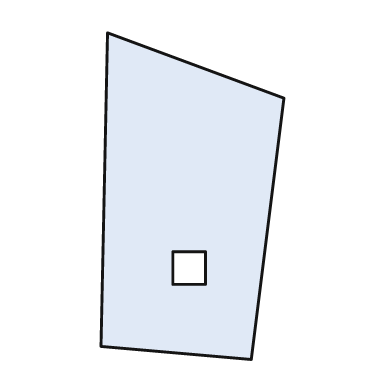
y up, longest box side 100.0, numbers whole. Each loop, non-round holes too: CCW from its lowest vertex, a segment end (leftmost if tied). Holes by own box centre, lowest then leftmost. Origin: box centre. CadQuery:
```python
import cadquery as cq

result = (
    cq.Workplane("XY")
    .moveTo(18.0, -50.0)
    .lineTo(28.0, 30.0)
    .lineTo(-26.0, 50.0)
    .lineTo(-28.0, -46.0)
    .close()
    .moveTo(-6.0, -27.0)
    .lineTo(4.0, -27.0)
    .lineTo(4.0, -17.0)
    .lineTo(-6.0, -17.0)
    .close()
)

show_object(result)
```